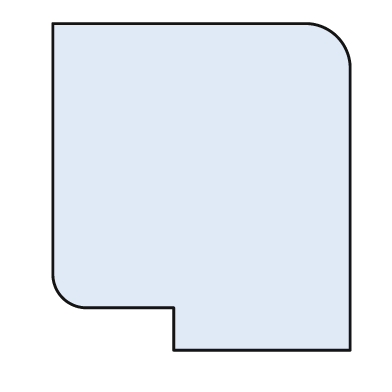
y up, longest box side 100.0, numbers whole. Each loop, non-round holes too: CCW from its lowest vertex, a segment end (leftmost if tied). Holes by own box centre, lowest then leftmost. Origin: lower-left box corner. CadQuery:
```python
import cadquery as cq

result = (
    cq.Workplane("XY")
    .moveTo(37.0, 0.0)
    .lineTo(91.0, 0.0)
    .lineTo(91.0, 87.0)
    .threePointArc((87.0, 96.0), (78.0, 100.0))
    .lineTo(0.0, 100.0)
    .lineTo(0.0, 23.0)
    .threePointArc((3.0, 16.0), (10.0, 13.0))
    .lineTo(37.0, 13.0)
    .close()
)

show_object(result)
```